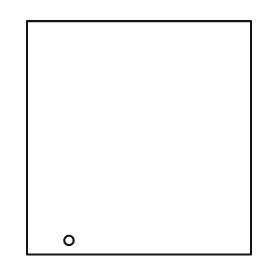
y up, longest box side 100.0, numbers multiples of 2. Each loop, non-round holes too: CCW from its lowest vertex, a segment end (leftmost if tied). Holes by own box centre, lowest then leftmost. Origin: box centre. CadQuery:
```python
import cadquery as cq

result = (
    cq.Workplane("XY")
    .moveTo(-48.0, -50.0)
    .lineTo(48.0, -50.0)
    .lineTo(48.0, 50.0)
    .lineTo(-48.0, 50.0)
    .close()
    .moveTo(-30.0, -44.0)
    .circle(2.0)
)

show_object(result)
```